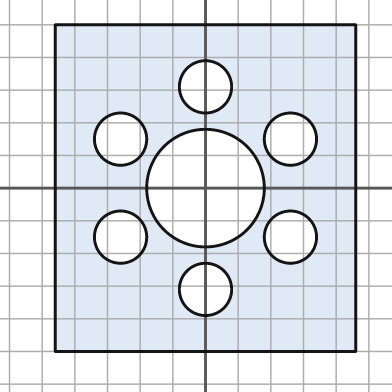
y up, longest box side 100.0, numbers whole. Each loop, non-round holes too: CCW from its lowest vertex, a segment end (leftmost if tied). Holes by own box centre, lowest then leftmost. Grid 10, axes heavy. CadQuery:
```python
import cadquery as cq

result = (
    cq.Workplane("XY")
    .moveTo(-46.0, -50.0)
    .lineTo(46.0, -50.0)
    .lineTo(46.0, 50.0)
    .lineTo(-46.0, 50.0)
    .close()
    .moveTo(0.0, -31.0)
    .circle(8.0)
    .moveTo(-26.0, -15.0)
    .circle(8.0)
    .moveTo(26.0, -15.0)
    .circle(8.0)
    .moveTo(0.0, 0.0)
    .circle(18.0)
    .moveTo(-26.0, 15.0)
    .circle(8.0)
    .moveTo(26.0, 15.0)
    .circle(8.0)
    .moveTo(0.0, 31.0)
    .circle(8.0)
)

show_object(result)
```